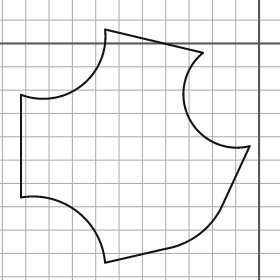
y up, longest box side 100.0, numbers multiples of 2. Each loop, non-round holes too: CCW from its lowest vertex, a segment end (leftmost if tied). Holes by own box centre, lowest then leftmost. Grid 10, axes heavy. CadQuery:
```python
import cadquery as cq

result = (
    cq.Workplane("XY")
    .moveTo(-66.0, -94.0)
    .lineTo(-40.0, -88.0)
    .threePointArc((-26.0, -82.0), (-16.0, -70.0))
    .lineTo(-4.0, -44.0)
    .threePointArc((-30.0, -32.0), (-24.0, -4.0))
    .lineTo(-66.0, 6.0)
    .threePointArc((-76.0, -18.0), (-102.0, -22.0))
    .lineTo(-102.0, -66.0)
    .threePointArc((-78.0, -72.0), (-66.0, -94.0))
    .close()
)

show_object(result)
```